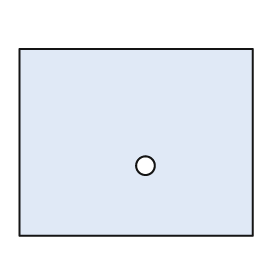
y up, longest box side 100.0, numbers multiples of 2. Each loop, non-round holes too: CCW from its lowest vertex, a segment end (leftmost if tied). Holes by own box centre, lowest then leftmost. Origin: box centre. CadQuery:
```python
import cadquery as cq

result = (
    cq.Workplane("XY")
    .moveTo(-50.0, -40.0)
    .lineTo(50.0, -40.0)
    .lineTo(50.0, 40.0)
    .lineTo(-50.0, 40.0)
    .close()
    .moveTo(4.0, -10.0)
    .circle(4.0)
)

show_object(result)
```